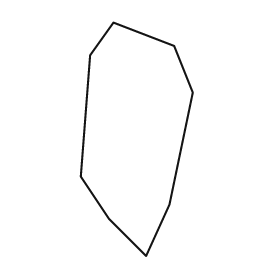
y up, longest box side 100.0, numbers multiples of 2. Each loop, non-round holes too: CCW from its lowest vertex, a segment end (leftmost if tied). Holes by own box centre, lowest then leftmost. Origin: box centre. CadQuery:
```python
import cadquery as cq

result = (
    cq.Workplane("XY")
    .moveTo(4.0, -50.0)
    .lineTo(14.0, -28.0)
    .lineTo(24.0, 20.0)
    .lineTo(16.0, 40.0)
    .lineTo(-10.0, 50.0)
    .lineTo(-20.0, 36.0)
    .lineTo(-24.0, -16.0)
    .lineTo(-12.0, -34.0)
    .close()
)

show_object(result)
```